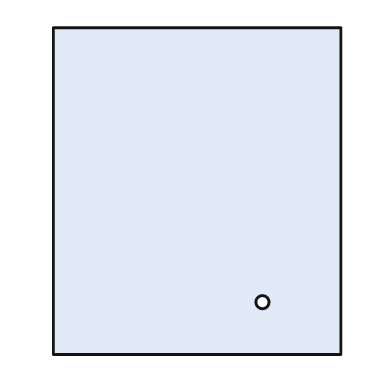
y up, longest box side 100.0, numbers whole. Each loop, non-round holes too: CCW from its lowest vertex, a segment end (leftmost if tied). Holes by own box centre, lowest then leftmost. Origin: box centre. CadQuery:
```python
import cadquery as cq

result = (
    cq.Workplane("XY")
    .moveTo(-44.0, -50.0)
    .lineTo(44.0, -50.0)
    .lineTo(44.0, 50.0)
    .lineTo(-44.0, 50.0)
    .close()
    .moveTo(20.0, -34.0)
    .circle(2.0)
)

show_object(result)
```